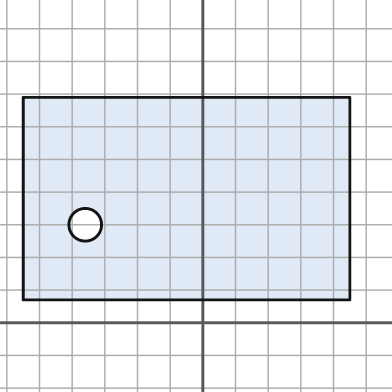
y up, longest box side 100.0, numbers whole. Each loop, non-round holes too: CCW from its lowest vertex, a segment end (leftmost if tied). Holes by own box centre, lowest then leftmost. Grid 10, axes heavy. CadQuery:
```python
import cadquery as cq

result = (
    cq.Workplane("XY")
    .moveTo(-55.0, 7.0)
    .lineTo(45.0, 7.0)
    .lineTo(45.0, 69.0)
    .lineTo(-55.0, 69.0)
    .close()
    .moveTo(-36.0, 30.0)
    .circle(5.0)
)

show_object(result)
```